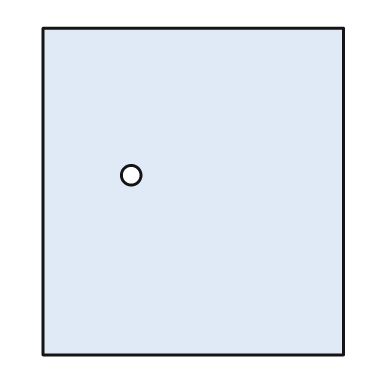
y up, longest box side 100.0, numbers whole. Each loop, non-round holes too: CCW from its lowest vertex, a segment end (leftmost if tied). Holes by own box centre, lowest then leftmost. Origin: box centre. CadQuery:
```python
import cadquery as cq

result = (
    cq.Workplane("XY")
    .moveTo(-46.0, -50.0)
    .lineTo(46.0, -50.0)
    .lineTo(46.0, 50.0)
    .lineTo(-46.0, 50.0)
    .close()
    .moveTo(-19.0, 5.0)
    .circle(3.0)
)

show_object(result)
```